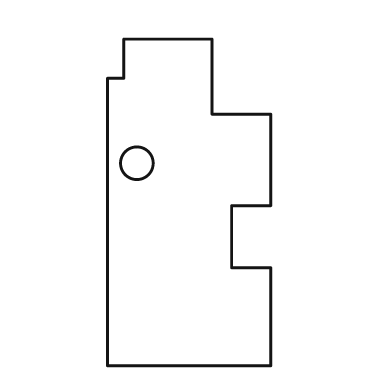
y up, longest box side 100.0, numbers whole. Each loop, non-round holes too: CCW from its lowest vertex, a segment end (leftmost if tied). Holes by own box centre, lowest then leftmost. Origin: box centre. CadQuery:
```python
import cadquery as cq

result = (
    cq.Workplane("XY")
    .moveTo(-25.0, -50.0)
    .lineTo(25.0, -50.0)
    .lineTo(25.0, -20.0)
    .lineTo(13.0, -20.0)
    .lineTo(13.0, -1.0)
    .lineTo(25.0, -1.0)
    .lineTo(25.0, 27.0)
    .lineTo(7.0, 27.0)
    .lineTo(7.0, 50.0)
    .lineTo(-20.0, 50.0)
    .lineTo(-20.0, 38.0)
    .lineTo(-25.0, 38.0)
    .close()
    .moveTo(-16.0, 12.0)
    .circle(5.0)
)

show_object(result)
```